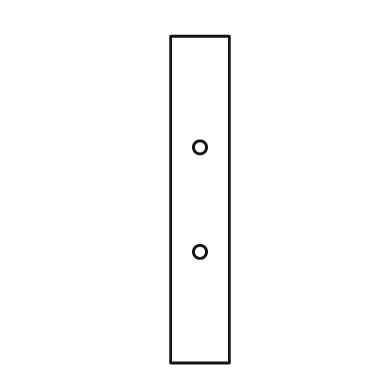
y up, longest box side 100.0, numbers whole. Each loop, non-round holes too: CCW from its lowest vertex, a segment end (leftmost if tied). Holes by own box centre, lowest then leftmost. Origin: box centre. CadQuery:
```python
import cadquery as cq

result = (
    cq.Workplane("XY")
    .moveTo(-9.0, -50.0)
    .lineTo(9.0, -50.0)
    .lineTo(9.0, 50.0)
    .lineTo(-9.0, 50.0)
    .close()
    .moveTo(0.0, -16.0)
    .circle(2.0)
    .moveTo(0.0, 16.0)
    .circle(2.0)
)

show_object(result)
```